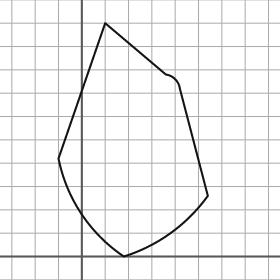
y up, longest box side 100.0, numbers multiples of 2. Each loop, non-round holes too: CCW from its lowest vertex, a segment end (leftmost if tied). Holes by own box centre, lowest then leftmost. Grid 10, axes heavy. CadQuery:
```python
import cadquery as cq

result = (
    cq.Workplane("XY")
    .moveTo(18.0, 0.0)
    .threePointArc((38.0, 10.0), (54.0, 26.0))
    .lineTo(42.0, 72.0)
    .threePointArc((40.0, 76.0), (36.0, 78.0))
    .lineTo(10.0, 100.0)
    .lineTo(-10.0, 42.0)
    .threePointArc((0.0, 18.0), (18.0, 0.0))
    .close()
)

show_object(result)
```